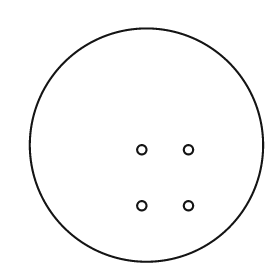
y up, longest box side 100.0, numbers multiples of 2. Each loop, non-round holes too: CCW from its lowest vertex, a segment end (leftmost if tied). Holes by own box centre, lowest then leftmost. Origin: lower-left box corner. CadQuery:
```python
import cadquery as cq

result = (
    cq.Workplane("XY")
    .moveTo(50.0, 50.0)
    .circle(50.0)
    .moveTo(48.0, 24.0)
    .circle(2.0)
    .moveTo(68.0, 24.0)
    .circle(2.0)
    .moveTo(48.0, 48.0)
    .circle(2.0)
    .moveTo(68.0, 48.0)
    .circle(2.0)
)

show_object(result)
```